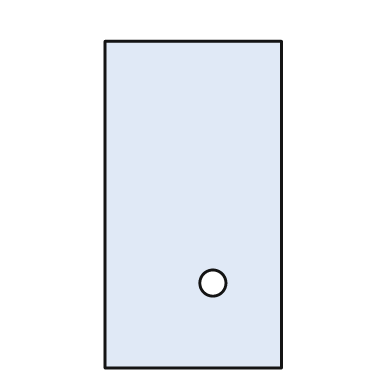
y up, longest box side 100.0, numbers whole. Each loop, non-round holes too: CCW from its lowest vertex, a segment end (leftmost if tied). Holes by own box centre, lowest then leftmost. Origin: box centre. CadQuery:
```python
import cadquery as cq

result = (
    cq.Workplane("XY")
    .moveTo(-27.0, -50.0)
    .lineTo(27.0, -50.0)
    .lineTo(27.0, 50.0)
    .lineTo(-27.0, 50.0)
    .close()
    .moveTo(6.0, -24.0)
    .circle(4.0)
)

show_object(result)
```